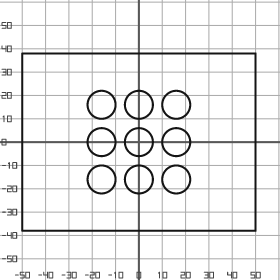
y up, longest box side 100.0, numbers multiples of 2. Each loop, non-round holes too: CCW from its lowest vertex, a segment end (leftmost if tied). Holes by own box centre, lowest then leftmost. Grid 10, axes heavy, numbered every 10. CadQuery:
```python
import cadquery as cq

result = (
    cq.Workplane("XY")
    .moveTo(-50.0, -38.0)
    .lineTo(50.0, -38.0)
    .lineTo(50.0, 38.0)
    .lineTo(-50.0, 38.0)
    .close()
    .moveTo(-16.0, -16.0)
    .circle(6.0)
    .moveTo(0.0, -16.0)
    .circle(6.0)
    .moveTo(16.0, -16.0)
    .circle(6.0)
    .moveTo(-16.0, 0.0)
    .circle(6.0)
    .moveTo(0.0, 0.0)
    .circle(6.0)
    .moveTo(16.0, 0.0)
    .circle(6.0)
    .moveTo(-16.0, 16.0)
    .circle(6.0)
    .moveTo(0.0, 16.0)
    .circle(6.0)
    .moveTo(16.0, 16.0)
    .circle(6.0)
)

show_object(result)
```